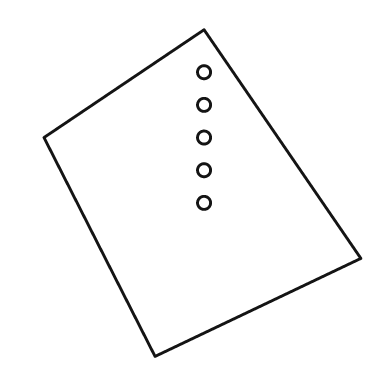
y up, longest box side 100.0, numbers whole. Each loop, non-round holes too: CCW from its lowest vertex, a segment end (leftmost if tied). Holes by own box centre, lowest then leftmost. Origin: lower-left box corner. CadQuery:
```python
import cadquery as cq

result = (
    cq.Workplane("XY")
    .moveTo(34.0, 0.0)
    .lineTo(97.0, 30.0)
    .lineTo(49.0, 100.0)
    .lineTo(0.0, 67.0)
    .close()
    .moveTo(49.0, 47.0)
    .circle(2.0)
    .moveTo(49.0, 57.0)
    .circle(2.0)
    .moveTo(49.0, 67.0)
    .circle(2.0)
    .moveTo(49.0, 77.0)
    .circle(2.0)
    .moveTo(49.0, 87.0)
    .circle(2.0)
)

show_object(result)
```